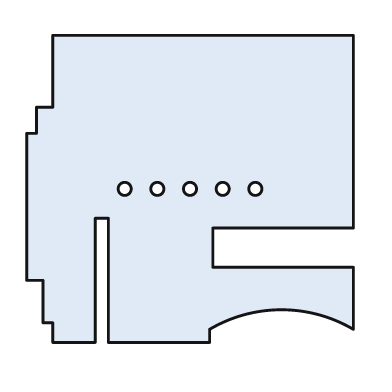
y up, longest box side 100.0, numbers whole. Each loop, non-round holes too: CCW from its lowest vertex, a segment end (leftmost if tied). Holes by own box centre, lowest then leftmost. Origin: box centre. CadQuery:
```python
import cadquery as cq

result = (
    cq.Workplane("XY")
    .moveTo(-42.0, -47.0)
    .lineTo(-29.0, -47.0)
    .lineTo(-29.0, -9.0)
    .lineTo(-25.0, -9.0)
    .lineTo(-25.0, -47.0)
    .lineTo(6.0, -47.0)
    .lineTo(6.0, -43.0)
    .threePointArc((28.0, -37.0), (50.0, -43.0))
    .lineTo(50.0, -24.0)
    .lineTo(7.0, -24.0)
    .lineTo(7.0, -12.0)
    .lineTo(50.0, -12.0)
    .lineTo(50.0, 47.0)
    .lineTo(-42.0, 47.0)
    .lineTo(-42.0, 25.0)
    .lineTo(-47.0, 25.0)
    .lineTo(-47.0, 17.0)
    .lineTo(-50.0, 17.0)
    .lineTo(-50.0, -28.0)
    .lineTo(-45.0, -28.0)
    .lineTo(-45.0, -41.0)
    .lineTo(-42.0, -41.0)
    .close()
    .moveTo(-20.0, 0.0)
    .circle(2.0)
    .moveTo(-10.0, 0.0)
    .circle(2.0)
    .moveTo(0.0, 0.0)
    .circle(2.0)
    .moveTo(10.0, 0.0)
    .circle(2.0)
    .moveTo(20.0, 0.0)
    .circle(2.0)
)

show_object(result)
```